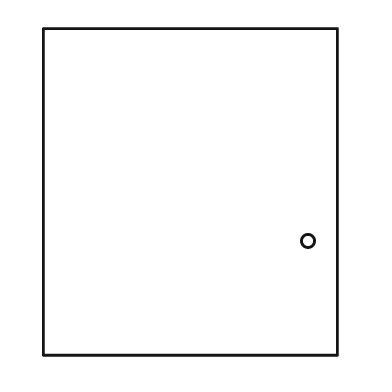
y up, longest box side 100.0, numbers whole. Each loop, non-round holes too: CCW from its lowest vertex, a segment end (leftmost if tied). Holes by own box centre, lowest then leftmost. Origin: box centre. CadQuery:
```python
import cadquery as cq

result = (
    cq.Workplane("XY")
    .moveTo(-45.0, -50.0)
    .lineTo(45.0, -50.0)
    .lineTo(45.0, 50.0)
    .lineTo(-45.0, 50.0)
    .close()
    .moveTo(36.0, -15.0)
    .circle(2.0)
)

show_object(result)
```